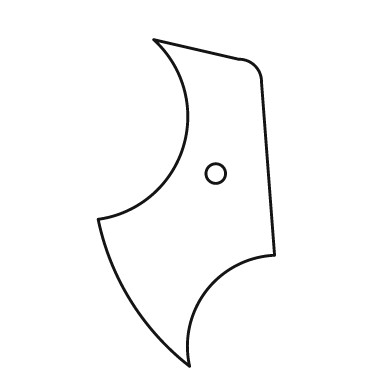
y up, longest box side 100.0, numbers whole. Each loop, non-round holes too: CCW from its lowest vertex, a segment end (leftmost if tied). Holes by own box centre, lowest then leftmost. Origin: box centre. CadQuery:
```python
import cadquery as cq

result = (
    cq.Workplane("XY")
    .moveTo(1.0, -50.0)
    .threePointArc((6.0, -27.0), (27.0, -16.0))
    .lineTo(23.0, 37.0)
    .threePointArc((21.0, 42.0), (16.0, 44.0))
    .lineTo(-10.0, 50.0)
    .threePointArc((-1.0, 17.0), (-27.0, -5.0))
    .threePointArc((-17.0, -30.0), (1.0, -50.0))
    .close()
    .moveTo(9.0, 9.0)
    .circle(3.0)
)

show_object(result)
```